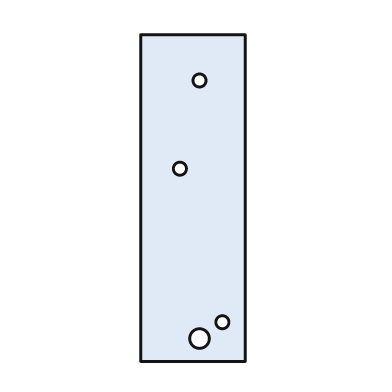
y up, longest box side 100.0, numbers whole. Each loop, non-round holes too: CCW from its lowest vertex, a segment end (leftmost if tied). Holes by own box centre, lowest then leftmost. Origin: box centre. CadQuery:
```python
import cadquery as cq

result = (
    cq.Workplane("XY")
    .moveTo(-16.0, -50.0)
    .lineTo(16.0, -50.0)
    .lineTo(16.0, 50.0)
    .lineTo(-16.0, 50.0)
    .close()
    .moveTo(2.0, -43.0)
    .circle(3.0)
    .moveTo(9.0, -38.0)
    .circle(2.0)
    .moveTo(-4.0, 9.0)
    .circle(2.0)
    .moveTo(2.0, 36.0)
    .circle(2.0)
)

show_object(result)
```